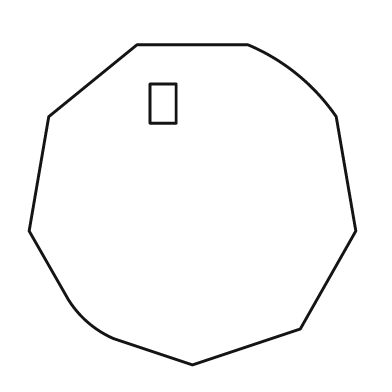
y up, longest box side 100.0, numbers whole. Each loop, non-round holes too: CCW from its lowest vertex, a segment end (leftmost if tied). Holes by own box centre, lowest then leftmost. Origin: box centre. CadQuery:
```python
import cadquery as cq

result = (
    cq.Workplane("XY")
    .moveTo(0.0, -49.0)
    .lineTo(33.0, -38.0)
    .lineTo(50.0, -8.0)
    .lineTo(44.0, 27.0)
    .threePointArc((32.0, 40.0), (17.0, 49.0))
    .lineTo(-17.0, 49.0)
    .lineTo(-44.0, 27.0)
    .lineTo(-50.0, -8.0)
    .lineTo(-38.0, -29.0)
    .threePointArc((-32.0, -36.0), (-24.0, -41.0))
    .close()
    .moveTo(-13.0, 25.0)
    .lineTo(-5.0, 25.0)
    .lineTo(-5.0, 37.0)
    .lineTo(-13.0, 37.0)
    .close()
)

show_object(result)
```